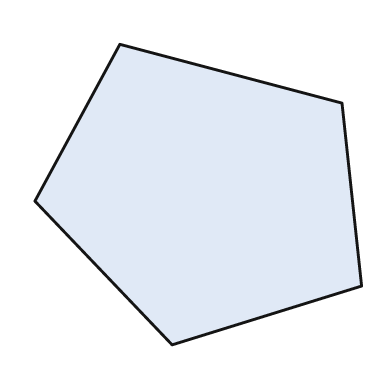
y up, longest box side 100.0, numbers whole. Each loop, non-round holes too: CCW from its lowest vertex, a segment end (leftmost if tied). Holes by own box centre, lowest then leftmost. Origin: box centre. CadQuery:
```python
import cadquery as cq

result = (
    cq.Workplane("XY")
    .moveTo(-8.0, -46.0)
    .lineTo(50.0, -28.0)
    .lineTo(44.0, 28.0)
    .lineTo(-24.0, 46.0)
    .lineTo(-50.0, -2.0)
    .close()
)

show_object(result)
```